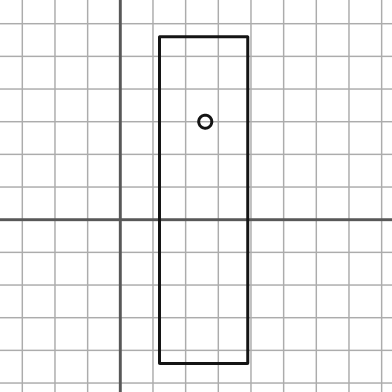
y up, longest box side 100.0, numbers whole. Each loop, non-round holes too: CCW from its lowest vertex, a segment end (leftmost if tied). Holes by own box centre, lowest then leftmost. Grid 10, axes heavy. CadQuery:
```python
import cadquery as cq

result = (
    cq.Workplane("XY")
    .moveTo(12.0, -44.0)
    .lineTo(39.0, -44.0)
    .lineTo(39.0, 56.0)
    .lineTo(12.0, 56.0)
    .close()
    .moveTo(26.0, 30.0)
    .circle(2.0)
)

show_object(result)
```